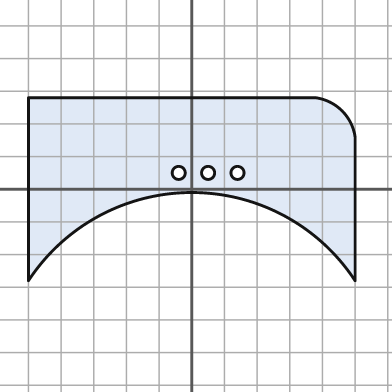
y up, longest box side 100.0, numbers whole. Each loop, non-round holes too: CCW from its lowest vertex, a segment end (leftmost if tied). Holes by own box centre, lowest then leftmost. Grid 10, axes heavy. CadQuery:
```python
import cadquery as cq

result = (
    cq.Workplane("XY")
    .moveTo(-50.0, -28.0)
    .threePointArc((0.0, -1.0), (50.0, -28.0))
    .lineTo(50.0, 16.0)
    .threePointArc((46.0, 24.0), (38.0, 28.0))
    .lineTo(-50.0, 28.0)
    .close()
    .moveTo(-4.0, 5.0)
    .circle(2.0)
    .moveTo(5.0, 5.0)
    .circle(2.0)
    .moveTo(14.0, 5.0)
    .circle(2.0)
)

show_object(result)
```